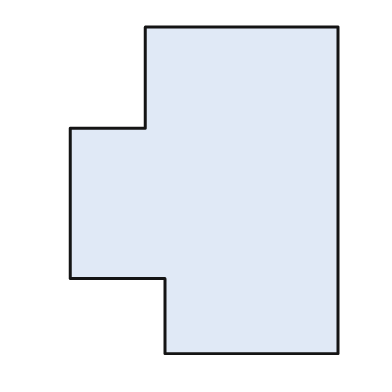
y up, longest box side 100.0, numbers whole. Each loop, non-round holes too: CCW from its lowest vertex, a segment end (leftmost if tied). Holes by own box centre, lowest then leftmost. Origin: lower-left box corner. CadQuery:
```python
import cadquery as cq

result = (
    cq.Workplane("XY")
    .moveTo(29.0, 0.0)
    .lineTo(82.0, 0.0)
    .lineTo(82.0, 100.0)
    .lineTo(23.0, 100.0)
    .lineTo(23.0, 69.0)
    .lineTo(0.0, 69.0)
    .lineTo(0.0, 23.0)
    .lineTo(29.0, 23.0)
    .close()
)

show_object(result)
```